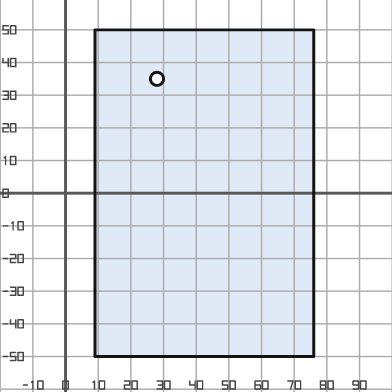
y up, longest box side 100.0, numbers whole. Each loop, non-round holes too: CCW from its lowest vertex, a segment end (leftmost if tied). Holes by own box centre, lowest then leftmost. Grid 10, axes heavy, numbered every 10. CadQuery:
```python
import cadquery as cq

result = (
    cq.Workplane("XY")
    .moveTo(9.0, -50.0)
    .lineTo(76.0, -50.0)
    .lineTo(76.0, 50.0)
    .lineTo(9.0, 50.0)
    .close()
    .moveTo(28.0, 35.0)
    .circle(2.0)
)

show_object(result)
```